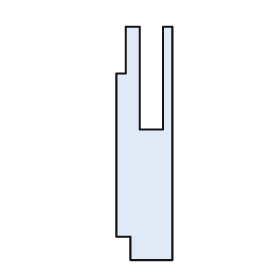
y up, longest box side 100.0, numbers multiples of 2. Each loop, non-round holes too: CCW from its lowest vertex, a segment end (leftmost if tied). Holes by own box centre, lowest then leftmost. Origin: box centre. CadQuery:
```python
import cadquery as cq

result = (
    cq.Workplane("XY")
    .moveTo(-6.0, -50.0)
    .lineTo(12.0, -50.0)
    .lineTo(12.0, 50.0)
    .lineTo(8.0, 50.0)
    .lineTo(8.0, 6.0)
    .lineTo(-2.0, 6.0)
    .lineTo(-2.0, 50.0)
    .lineTo(-8.0, 50.0)
    .lineTo(-8.0, 30.0)
    .lineTo(-12.0, 30.0)
    .lineTo(-12.0, -40.0)
    .lineTo(-6.0, -40.0)
    .close()
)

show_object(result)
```